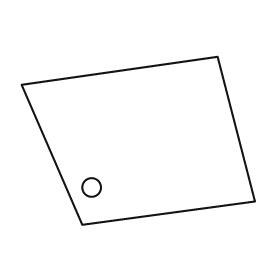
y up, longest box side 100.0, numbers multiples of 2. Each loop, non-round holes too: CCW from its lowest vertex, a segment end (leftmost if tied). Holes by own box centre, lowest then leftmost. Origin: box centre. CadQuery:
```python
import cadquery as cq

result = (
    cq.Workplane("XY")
    .moveTo(-24.0, -36.0)
    .lineTo(50.0, -26.0)
    .lineTo(34.0, 36.0)
    .lineTo(-50.0, 24.0)
    .close()
    .moveTo(-20.0, -20.0)
    .circle(4.0)
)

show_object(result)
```